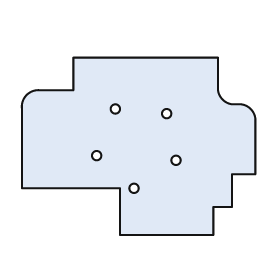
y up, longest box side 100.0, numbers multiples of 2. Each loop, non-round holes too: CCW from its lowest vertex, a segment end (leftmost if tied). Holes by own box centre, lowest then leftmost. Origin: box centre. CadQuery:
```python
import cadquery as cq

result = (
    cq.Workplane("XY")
    .moveTo(-8.0, -38.0)
    .lineTo(32.0, -38.0)
    .lineTo(32.0, -26.0)
    .lineTo(40.0, -26.0)
    .lineTo(40.0, -12.0)
    .lineTo(50.0, -12.0)
    .lineTo(50.0, 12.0)
    .threePointArc((48.0, 16.0), (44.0, 18.0))
    .lineTo(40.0, 18.0)
    .threePointArc((36.0, 20.0), (34.0, 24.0))
    .lineTo(34.0, 38.0)
    .lineTo(-28.0, 38.0)
    .lineTo(-28.0, 24.0)
    .lineTo(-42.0, 24.0)
    .threePointArc((-48.0, 22.0), (-50.0, 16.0))
    .lineTo(-50.0, -18.0)
    .lineTo(-8.0, -18.0)
    .close()
    .moveTo(-2.0, -18.0)
    .circle(2.0)
    .moveTo(16.0, -6.0)
    .circle(2.0)
    .moveTo(-18.0, -4.0)
    .circle(2.0)
    .moveTo(12.0, 14.0)
    .circle(2.0)
    .moveTo(-10.0, 16.0)
    .circle(2.0)
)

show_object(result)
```